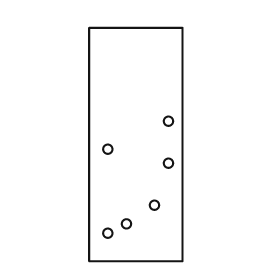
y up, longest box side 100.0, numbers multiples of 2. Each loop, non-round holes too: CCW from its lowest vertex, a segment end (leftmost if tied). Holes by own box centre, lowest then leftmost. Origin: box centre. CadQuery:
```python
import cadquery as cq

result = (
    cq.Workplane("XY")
    .moveTo(-20.0, -50.0)
    .lineTo(20.0, -50.0)
    .lineTo(20.0, 50.0)
    .lineTo(-20.0, 50.0)
    .close()
    .moveTo(-12.0, -38.0)
    .circle(2.0)
    .moveTo(-4.0, -34.0)
    .circle(2.0)
    .moveTo(8.0, -26.0)
    .circle(2.0)
    .moveTo(14.0, -8.0)
    .circle(2.0)
    .moveTo(-12.0, -2.0)
    .circle(2.0)
    .moveTo(14.0, 10.0)
    .circle(2.0)
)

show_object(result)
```